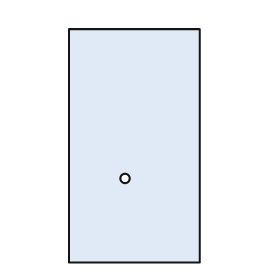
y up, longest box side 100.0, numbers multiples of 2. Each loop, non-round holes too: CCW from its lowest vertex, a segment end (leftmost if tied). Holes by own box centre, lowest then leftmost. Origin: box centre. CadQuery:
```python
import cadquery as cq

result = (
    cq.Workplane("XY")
    .moveTo(-28.0, -50.0)
    .lineTo(28.0, -50.0)
    .lineTo(28.0, 50.0)
    .lineTo(-28.0, 50.0)
    .close()
    .moveTo(-4.0, -14.0)
    .circle(2.0)
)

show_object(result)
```